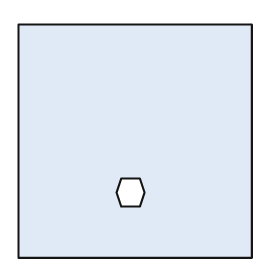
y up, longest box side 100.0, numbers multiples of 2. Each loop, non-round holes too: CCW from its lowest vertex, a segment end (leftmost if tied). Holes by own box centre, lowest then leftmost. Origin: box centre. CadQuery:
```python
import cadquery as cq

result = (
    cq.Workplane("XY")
    .moveTo(-50.0, -50.0)
    .lineTo(50.0, -50.0)
    .lineTo(50.0, 50.0)
    .lineTo(-50.0, 50.0)
    .close()
    .moveTo(-6.0, -28.0)
    .lineTo(2.0, -28.0)
    .lineTo(4.0, -22.0)
    .lineTo(2.0, -16.0)
    .lineTo(-6.0, -16.0)
    .lineTo(-8.0, -22.0)
    .close()
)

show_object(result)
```